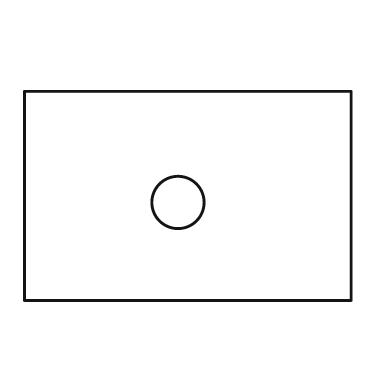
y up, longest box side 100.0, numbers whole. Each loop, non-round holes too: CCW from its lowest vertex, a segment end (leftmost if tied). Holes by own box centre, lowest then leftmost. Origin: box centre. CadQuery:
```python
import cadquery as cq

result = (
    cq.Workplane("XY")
    .moveTo(-50.0, -32.0)
    .lineTo(50.0, -32.0)
    .lineTo(50.0, 32.0)
    .lineTo(-50.0, 32.0)
    .close()
    .moveTo(-3.0, -2.0)
    .circle(8.0)
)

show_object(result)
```